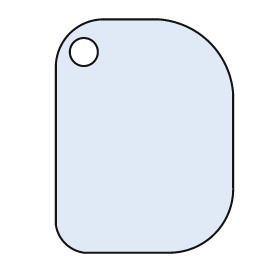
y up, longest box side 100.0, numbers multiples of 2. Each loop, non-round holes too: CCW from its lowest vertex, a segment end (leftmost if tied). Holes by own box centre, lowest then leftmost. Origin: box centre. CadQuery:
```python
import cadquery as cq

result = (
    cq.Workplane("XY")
    .moveTo(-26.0, -50.0)
    .lineTo(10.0, -50.0)
    .threePointArc((30.0, -42.0), (38.0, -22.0))
    .lineTo(38.0, 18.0)
    .threePointArc((28.0, 40.0), (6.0, 50.0))
    .lineTo(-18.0, 50.0)
    .threePointArc((-32.0, 44.0), (-38.0, 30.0))
    .lineTo(-38.0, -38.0)
    .threePointArc((-34.0, -46.0), (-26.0, -50.0))
    .close()
    .moveTo(-26.0, 36.0)
    .circle(6.0)
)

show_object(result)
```